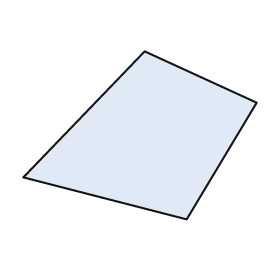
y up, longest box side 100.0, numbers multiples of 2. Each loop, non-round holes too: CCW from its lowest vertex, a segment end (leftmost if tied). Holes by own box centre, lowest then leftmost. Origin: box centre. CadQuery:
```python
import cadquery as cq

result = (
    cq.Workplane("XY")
    .moveTo(20.0, -36.0)
    .lineTo(50.0, 14.0)
    .lineTo(2.0, 36.0)
    .lineTo(-50.0, -18.0)
    .close()
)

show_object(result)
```